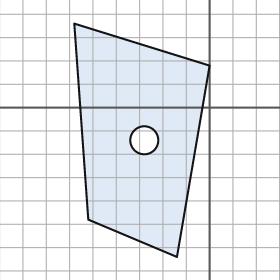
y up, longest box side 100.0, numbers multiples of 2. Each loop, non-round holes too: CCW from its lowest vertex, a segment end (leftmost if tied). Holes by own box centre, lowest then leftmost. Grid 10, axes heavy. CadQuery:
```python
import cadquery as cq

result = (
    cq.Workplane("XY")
    .moveTo(-14.0, -64.0)
    .lineTo(0.0, 18.0)
    .lineTo(-58.0, 36.0)
    .lineTo(-52.0, -48.0)
    .close()
    .moveTo(-28.0, -14.0)
    .circle(6.0)
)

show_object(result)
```